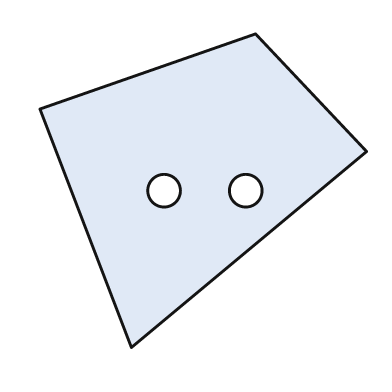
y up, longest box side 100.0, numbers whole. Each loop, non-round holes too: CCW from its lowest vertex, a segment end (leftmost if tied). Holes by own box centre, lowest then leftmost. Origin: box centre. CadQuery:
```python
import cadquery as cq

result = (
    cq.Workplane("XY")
    .moveTo(-22.0, -48.0)
    .lineTo(50.0, 12.0)
    .lineTo(16.0, 48.0)
    .lineTo(-50.0, 25.0)
    .close()
    .moveTo(-12.0, 0.0)
    .circle(5.0)
    .moveTo(13.0, 0.0)
    .circle(5.0)
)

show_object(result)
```